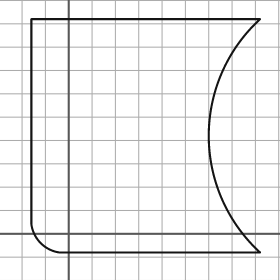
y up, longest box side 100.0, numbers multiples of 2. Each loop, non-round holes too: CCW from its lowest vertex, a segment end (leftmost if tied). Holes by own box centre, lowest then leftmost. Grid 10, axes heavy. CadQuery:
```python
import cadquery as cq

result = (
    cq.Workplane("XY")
    .moveTo(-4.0, -8.0)
    .lineTo(82.0, -8.0)
    .threePointArc((60.0, 42.0), (82.0, 92.0))
    .lineTo(-16.0, 92.0)
    .lineTo(-16.0, 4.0)
    .threePointArc((-12.0, -4.0), (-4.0, -8.0))
    .close()
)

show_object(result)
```